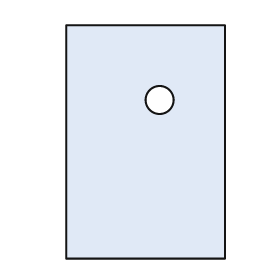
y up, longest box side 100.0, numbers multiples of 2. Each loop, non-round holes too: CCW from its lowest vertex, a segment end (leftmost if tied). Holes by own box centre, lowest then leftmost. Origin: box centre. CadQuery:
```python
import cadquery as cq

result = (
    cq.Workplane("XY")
    .moveTo(-34.0, -50.0)
    .lineTo(34.0, -50.0)
    .lineTo(34.0, 50.0)
    .lineTo(-34.0, 50.0)
    .close()
    .moveTo(6.0, 18.0)
    .circle(6.0)
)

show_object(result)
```